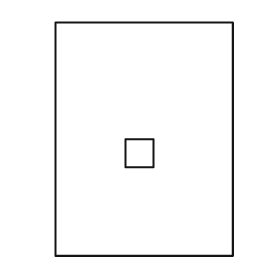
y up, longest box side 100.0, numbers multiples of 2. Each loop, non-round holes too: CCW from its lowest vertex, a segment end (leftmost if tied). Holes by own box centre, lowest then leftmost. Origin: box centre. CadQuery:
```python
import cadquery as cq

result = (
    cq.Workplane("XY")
    .moveTo(-38.0, -50.0)
    .lineTo(38.0, -50.0)
    .lineTo(38.0, 50.0)
    .lineTo(-38.0, 50.0)
    .close()
    .moveTo(-8.0, -12.0)
    .lineTo(4.0, -12.0)
    .lineTo(4.0, 0.0)
    .lineTo(-8.0, 0.0)
    .close()
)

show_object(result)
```